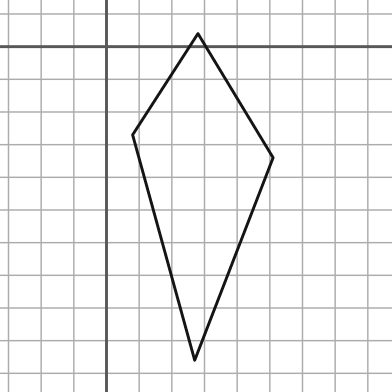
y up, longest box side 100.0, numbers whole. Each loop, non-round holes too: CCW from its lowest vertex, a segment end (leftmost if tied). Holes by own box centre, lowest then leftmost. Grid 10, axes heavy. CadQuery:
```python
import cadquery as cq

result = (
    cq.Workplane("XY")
    .moveTo(27.0, -96.0)
    .lineTo(51.0, -34.0)
    .lineTo(28.0, 4.0)
    .lineTo(8.0, -27.0)
    .close()
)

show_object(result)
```